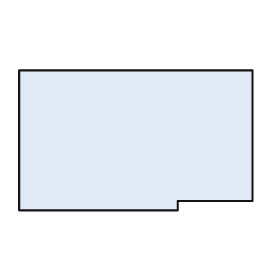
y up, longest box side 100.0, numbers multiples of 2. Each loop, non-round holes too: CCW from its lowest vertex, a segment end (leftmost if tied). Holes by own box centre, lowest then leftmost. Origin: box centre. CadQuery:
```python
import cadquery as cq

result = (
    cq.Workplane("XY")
    .moveTo(-50.0, -30.0)
    .lineTo(18.0, -30.0)
    .lineTo(18.0, -26.0)
    .lineTo(50.0, -26.0)
    .lineTo(50.0, 30.0)
    .lineTo(-50.0, 30.0)
    .close()
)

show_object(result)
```